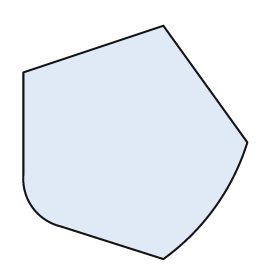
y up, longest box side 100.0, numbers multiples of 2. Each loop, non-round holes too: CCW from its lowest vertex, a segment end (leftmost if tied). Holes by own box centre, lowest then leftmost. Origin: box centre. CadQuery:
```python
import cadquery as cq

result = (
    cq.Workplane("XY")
    .moveTo(12.0, -50.0)
    .threePointArc((34.0, -28.0), (48.0, 0.0))
    .lineTo(12.0, 50.0)
    .lineTo(-48.0, 30.0)
    .lineTo(-48.0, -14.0)
    .threePointArc((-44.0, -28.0), (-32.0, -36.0))
    .close()
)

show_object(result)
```